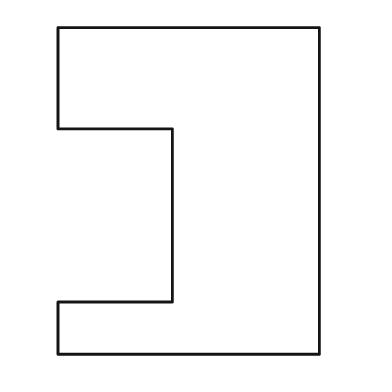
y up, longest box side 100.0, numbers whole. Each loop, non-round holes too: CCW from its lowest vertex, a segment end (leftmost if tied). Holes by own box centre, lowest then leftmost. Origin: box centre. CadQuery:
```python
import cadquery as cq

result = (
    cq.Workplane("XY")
    .moveTo(-40.0, -50.0)
    .lineTo(40.0, -50.0)
    .lineTo(40.0, 50.0)
    .lineTo(-40.0, 50.0)
    .lineTo(-40.0, 19.0)
    .lineTo(-5.0, 19.0)
    .lineTo(-5.0, -34.0)
    .lineTo(-40.0, -34.0)
    .close()
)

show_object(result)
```